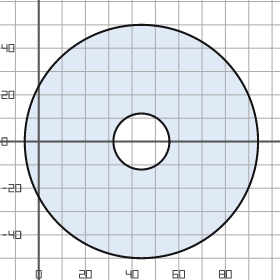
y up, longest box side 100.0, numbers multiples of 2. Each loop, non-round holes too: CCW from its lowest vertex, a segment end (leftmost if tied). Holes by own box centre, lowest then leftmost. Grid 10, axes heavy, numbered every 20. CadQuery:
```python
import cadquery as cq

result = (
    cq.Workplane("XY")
    .moveTo(44.0, 0.0)
    .circle(50.0)
    .moveTo(44.0, 0.0)
    .circle(12.0)
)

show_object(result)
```